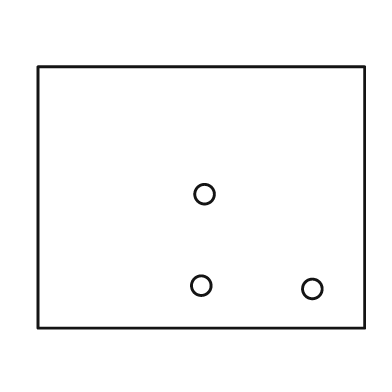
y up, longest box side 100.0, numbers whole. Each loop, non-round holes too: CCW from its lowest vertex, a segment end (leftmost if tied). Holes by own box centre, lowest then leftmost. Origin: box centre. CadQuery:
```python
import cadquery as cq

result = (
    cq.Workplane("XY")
    .moveTo(-50.0, -40.0)
    .lineTo(50.0, -40.0)
    .lineTo(50.0, 40.0)
    .lineTo(-50.0, 40.0)
    .close()
    .moveTo(34.0, -28.0)
    .circle(3.0)
    .moveTo(0.0, -27.0)
    .circle(3.0)
    .moveTo(1.0, 1.0)
    .circle(3.0)
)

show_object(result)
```